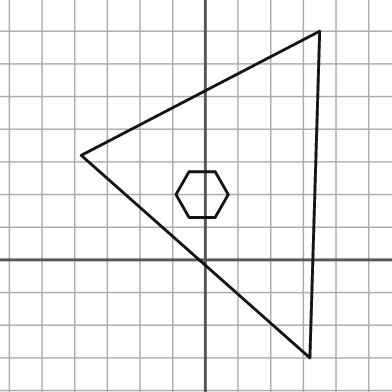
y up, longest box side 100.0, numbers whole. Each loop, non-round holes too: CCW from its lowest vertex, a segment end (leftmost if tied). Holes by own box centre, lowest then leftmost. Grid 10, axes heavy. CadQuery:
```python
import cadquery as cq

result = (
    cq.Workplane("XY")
    .moveTo(32.0, -30.0)
    .lineTo(35.0, 70.0)
    .lineTo(-38.0, 32.0)
    .close()
    .moveTo(-5.0, 13.0)
    .lineTo(3.0, 13.0)
    .lineTo(7.0, 20.0)
    .lineTo(3.0, 27.0)
    .lineTo(-5.0, 27.0)
    .lineTo(-9.0, 20.0)
    .close()
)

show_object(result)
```